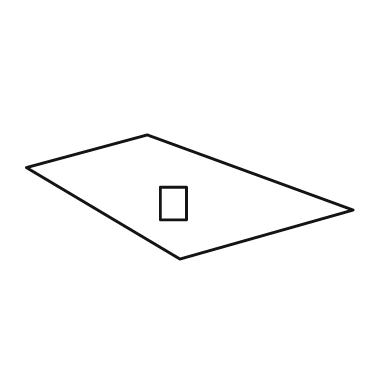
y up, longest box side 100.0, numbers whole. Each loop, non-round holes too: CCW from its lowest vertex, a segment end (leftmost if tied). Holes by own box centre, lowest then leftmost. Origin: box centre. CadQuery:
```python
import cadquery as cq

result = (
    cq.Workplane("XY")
    .moveTo(-3.0, -19.0)
    .lineTo(50.0, -4.0)
    .lineTo(-13.0, 19.0)
    .lineTo(-50.0, 9.0)
    .close()
    .moveTo(-9.0, -7.0)
    .lineTo(-1.0, -7.0)
    .lineTo(-1.0, 3.0)
    .lineTo(-9.0, 3.0)
    .close()
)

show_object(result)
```